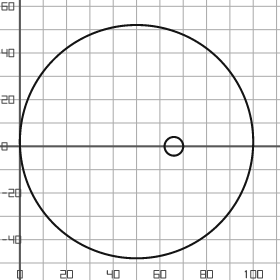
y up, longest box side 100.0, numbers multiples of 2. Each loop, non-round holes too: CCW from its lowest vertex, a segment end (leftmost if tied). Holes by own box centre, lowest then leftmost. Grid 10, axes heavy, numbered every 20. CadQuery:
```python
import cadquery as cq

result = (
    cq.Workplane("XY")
    .moveTo(50.0, 2.0)
    .circle(50.0)
    .moveTo(66.0, 0.0)
    .circle(4.0)
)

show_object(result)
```